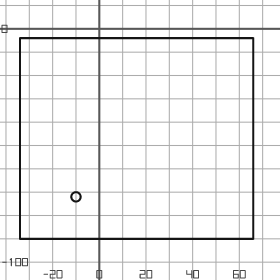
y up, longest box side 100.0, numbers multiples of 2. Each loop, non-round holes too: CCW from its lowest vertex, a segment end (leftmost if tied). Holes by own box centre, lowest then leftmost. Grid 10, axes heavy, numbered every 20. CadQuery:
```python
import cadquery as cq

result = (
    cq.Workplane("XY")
    .moveTo(-34.0, -90.0)
    .lineTo(66.0, -90.0)
    .lineTo(66.0, -4.0)
    .lineTo(-34.0, -4.0)
    .close()
    .moveTo(-10.0, -72.0)
    .circle(2.0)
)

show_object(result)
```